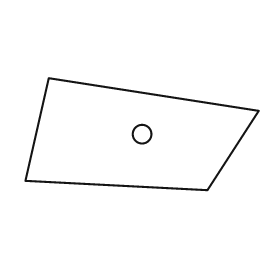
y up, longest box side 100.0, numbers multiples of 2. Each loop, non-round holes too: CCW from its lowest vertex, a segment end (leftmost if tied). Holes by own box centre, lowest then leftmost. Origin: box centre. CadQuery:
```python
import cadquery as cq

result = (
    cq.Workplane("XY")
    .moveTo(28.0, -24.0)
    .lineTo(50.0, 10.0)
    .lineTo(-40.0, 24.0)
    .lineTo(-50.0, -20.0)
    .close()
    .moveTo(0.0, 0.0)
    .circle(4.0)
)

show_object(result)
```